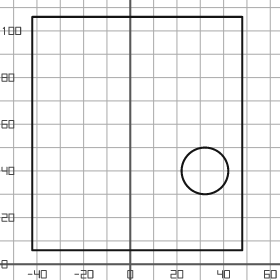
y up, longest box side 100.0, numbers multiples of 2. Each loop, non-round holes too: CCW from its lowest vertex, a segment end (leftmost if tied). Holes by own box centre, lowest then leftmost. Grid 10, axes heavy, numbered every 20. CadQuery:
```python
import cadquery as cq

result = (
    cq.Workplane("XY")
    .moveTo(-42.0, 6.0)
    .lineTo(48.0, 6.0)
    .lineTo(48.0, 106.0)
    .lineTo(-42.0, 106.0)
    .close()
    .moveTo(32.0, 40.0)
    .circle(10.0)
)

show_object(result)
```